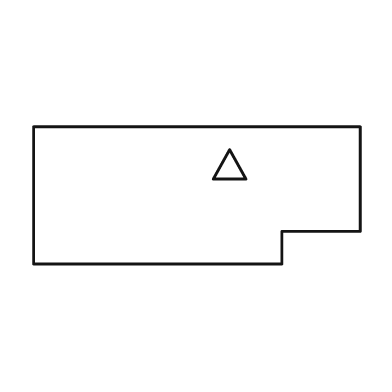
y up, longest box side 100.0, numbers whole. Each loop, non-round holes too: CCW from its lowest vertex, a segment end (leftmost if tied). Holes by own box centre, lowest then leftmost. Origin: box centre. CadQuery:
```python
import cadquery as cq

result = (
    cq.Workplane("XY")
    .moveTo(-50.0, -21.0)
    .lineTo(26.0, -21.0)
    .lineTo(26.0, -11.0)
    .lineTo(50.0, -11.0)
    .lineTo(50.0, 21.0)
    .lineTo(-50.0, 21.0)
    .close()
    .moveTo(5.0, 5.0)
    .lineTo(15.0, 5.0)
    .lineTo(10.0, 14.0)
    .close()
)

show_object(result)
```